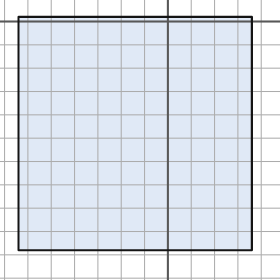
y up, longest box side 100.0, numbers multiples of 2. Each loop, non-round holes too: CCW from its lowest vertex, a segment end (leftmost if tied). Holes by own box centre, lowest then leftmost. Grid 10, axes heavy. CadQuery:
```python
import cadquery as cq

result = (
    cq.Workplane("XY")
    .moveTo(-64.0, -98.0)
    .lineTo(36.0, -98.0)
    .lineTo(36.0, 2.0)
    .lineTo(-64.0, 2.0)
    .close()
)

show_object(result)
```